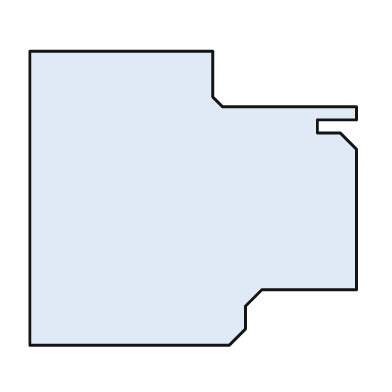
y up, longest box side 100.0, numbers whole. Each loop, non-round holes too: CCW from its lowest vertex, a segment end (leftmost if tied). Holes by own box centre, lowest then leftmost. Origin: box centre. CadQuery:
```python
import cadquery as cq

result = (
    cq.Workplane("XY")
    .moveTo(-50.0, -45.0)
    .lineTo(11.0, -45.0)
    .lineTo(16.0, -40.0)
    .lineTo(16.0, -33.0)
    .lineTo(21.0, -28.0)
    .lineTo(50.0, -28.0)
    .lineTo(50.0, 15.0)
    .lineTo(45.0, 20.0)
    .lineTo(38.0, 20.0)
    .lineTo(38.0, 24.0)
    .lineTo(50.0, 24.0)
    .lineTo(50.0, 28.0)
    .lineTo(9.0, 28.0)
    .lineTo(6.0, 31.0)
    .lineTo(6.0, 45.0)
    .lineTo(-50.0, 45.0)
    .close()
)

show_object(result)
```